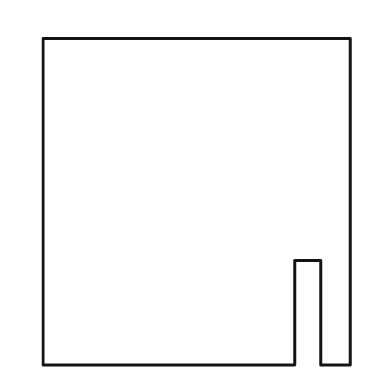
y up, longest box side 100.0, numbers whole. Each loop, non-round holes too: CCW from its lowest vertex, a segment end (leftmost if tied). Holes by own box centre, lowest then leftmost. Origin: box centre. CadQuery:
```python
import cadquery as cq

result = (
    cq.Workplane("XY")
    .moveTo(-47.0, -50.0)
    .lineTo(30.0, -50.0)
    .lineTo(30.0, -18.0)
    .lineTo(38.0, -18.0)
    .lineTo(38.0, -50.0)
    .lineTo(47.0, -50.0)
    .lineTo(47.0, 50.0)
    .lineTo(-47.0, 50.0)
    .close()
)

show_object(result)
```